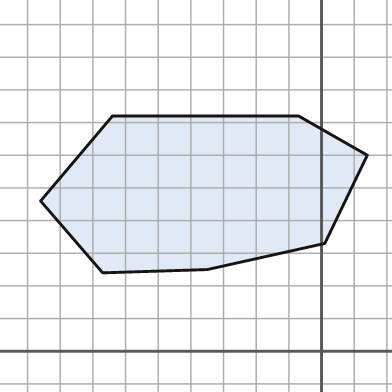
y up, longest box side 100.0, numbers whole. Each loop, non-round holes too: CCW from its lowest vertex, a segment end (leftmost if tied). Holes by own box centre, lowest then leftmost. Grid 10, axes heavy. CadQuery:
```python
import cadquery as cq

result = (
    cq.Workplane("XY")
    .moveTo(-67.0, 24.0)
    .lineTo(-35.0, 25.0)
    .lineTo(1.0, 33.0)
    .lineTo(14.0, 60.0)
    .lineTo(-7.0, 72.0)
    .lineTo(-64.0, 72.0)
    .lineTo(-86.0, 46.0)
    .close()
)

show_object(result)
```